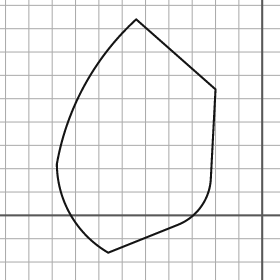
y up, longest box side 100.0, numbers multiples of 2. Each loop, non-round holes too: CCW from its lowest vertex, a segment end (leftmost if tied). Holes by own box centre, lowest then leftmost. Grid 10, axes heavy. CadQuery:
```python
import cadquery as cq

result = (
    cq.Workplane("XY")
    .moveTo(-66.0, -16.0)
    .lineTo(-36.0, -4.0)
    .threePointArc((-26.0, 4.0), (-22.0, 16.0))
    .lineTo(-20.0, 54.0)
    .lineTo(-54.0, 84.0)
    .threePointArc((-76.0, 56.0), (-88.0, 22.0))
    .threePointArc((-82.0, 0.0), (-66.0, -16.0))
    .close()
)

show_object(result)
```